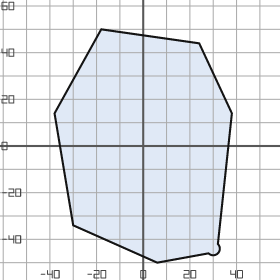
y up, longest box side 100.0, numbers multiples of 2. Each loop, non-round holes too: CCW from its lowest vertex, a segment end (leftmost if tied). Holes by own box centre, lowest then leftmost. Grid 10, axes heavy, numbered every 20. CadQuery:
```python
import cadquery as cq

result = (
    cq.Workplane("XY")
    .moveTo(6.0, -50.0)
    .lineTo(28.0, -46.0)
    .threePointArc((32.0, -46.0), (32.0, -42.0))
    .lineTo(38.0, 14.0)
    .lineTo(24.0, 44.0)
    .lineTo(-18.0, 50.0)
    .lineTo(-38.0, 14.0)
    .lineTo(-30.0, -34.0)
    .close()
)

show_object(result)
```